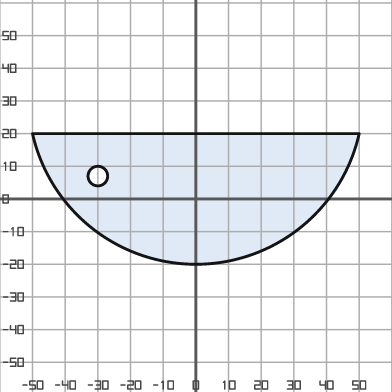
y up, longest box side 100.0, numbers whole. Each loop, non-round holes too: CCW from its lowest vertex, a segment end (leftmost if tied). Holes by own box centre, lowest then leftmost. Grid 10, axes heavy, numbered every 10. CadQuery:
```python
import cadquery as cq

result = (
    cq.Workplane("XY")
    .moveTo(-50.0, 20.0)
    .threePointArc((0.0, -20.0), (50.0, 20.0))
    .close()
    .moveTo(-30.0, 7.0)
    .circle(3.0)
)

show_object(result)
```